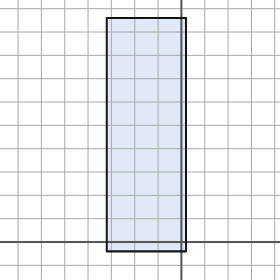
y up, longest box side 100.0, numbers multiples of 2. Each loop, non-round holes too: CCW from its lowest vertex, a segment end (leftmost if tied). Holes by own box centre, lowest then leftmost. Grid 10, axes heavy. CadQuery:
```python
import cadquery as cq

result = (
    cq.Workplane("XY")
    .moveTo(-32.0, -4.0)
    .lineTo(2.0, -4.0)
    .lineTo(2.0, 96.0)
    .lineTo(-32.0, 96.0)
    .close()
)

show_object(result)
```